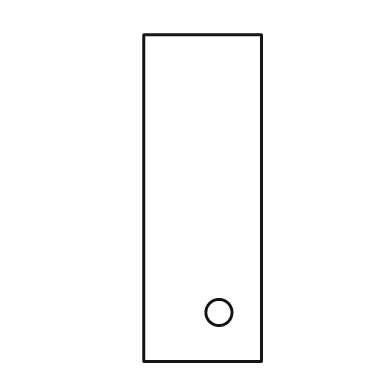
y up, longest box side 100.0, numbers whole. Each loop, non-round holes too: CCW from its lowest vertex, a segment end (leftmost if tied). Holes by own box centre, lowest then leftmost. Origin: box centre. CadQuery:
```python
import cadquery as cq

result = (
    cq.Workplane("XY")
    .moveTo(-18.0, -50.0)
    .lineTo(18.0, -50.0)
    .lineTo(18.0, 50.0)
    .lineTo(-18.0, 50.0)
    .close()
    .moveTo(5.0, -35.0)
    .circle(4.0)
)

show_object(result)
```